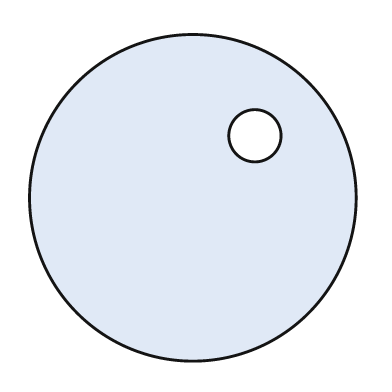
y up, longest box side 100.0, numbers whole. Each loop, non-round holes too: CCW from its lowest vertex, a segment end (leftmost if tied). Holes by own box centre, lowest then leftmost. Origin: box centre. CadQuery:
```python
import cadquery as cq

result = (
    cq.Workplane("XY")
    .moveTo(0.0, 0.0)
    .circle(50.0)
    .moveTo(19.0, 19.0)
    .circle(8.0)
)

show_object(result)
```